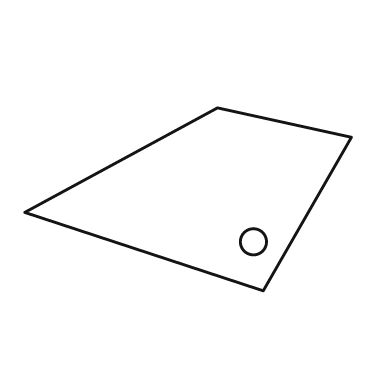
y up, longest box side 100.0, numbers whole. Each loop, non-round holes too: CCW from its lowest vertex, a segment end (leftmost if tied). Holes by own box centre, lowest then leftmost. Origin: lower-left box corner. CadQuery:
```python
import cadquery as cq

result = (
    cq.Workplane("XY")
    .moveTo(73.0, 0.0)
    .lineTo(100.0, 47.0)
    .lineTo(59.0, 56.0)
    .lineTo(0.0, 24.0)
    .close()
    .moveTo(70.0, 15.0)
    .circle(4.0)
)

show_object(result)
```